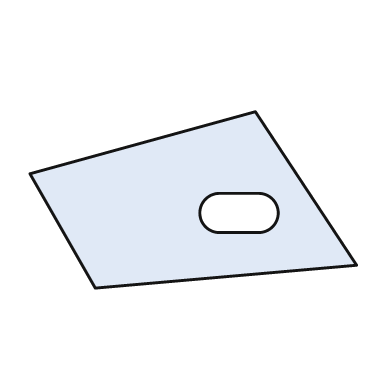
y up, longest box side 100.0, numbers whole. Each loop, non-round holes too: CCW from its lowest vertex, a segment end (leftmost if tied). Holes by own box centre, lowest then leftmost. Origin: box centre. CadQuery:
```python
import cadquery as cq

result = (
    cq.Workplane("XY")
    .moveTo(-30.0, -27.0)
    .lineTo(50.0, -20.0)
    .lineTo(19.0, 27.0)
    .lineTo(-50.0, 8.0)
    .close()
    .moveTo(8.0, -10.0)
    .lineTo(20.0, -10.0)
    .threePointArc((26.0, -4.0), (20.0, 2.0))
    .lineTo(8.0, 2.0)
    .threePointArc((2.0, -4.0), (8.0, -10.0))
    .close()
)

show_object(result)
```